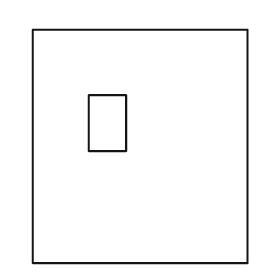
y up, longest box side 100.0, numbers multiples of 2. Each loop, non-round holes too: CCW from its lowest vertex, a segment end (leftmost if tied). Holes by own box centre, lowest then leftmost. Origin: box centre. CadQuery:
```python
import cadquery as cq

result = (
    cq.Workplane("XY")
    .moveTo(-46.0, -50.0)
    .lineTo(46.0, -50.0)
    .lineTo(46.0, 50.0)
    .lineTo(-46.0, 50.0)
    .close()
    .moveTo(-22.0, -2.0)
    .lineTo(-6.0, -2.0)
    .lineTo(-6.0, 22.0)
    .lineTo(-22.0, 22.0)
    .close()
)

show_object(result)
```